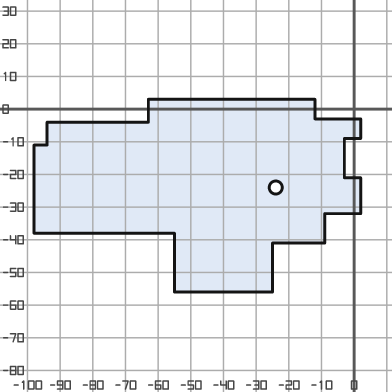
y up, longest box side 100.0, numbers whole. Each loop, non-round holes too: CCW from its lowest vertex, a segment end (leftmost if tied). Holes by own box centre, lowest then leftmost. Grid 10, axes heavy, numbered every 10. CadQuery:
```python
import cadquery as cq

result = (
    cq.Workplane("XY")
    .moveTo(-55.0, -56.0)
    .lineTo(-25.0, -56.0)
    .lineTo(-25.0, -41.0)
    .lineTo(-9.0, -41.0)
    .lineTo(-9.0, -32.0)
    .lineTo(2.0, -32.0)
    .lineTo(2.0, -21.0)
    .lineTo(-3.0, -21.0)
    .lineTo(-3.0, -9.0)
    .lineTo(2.0, -9.0)
    .lineTo(2.0, -3.0)
    .lineTo(-12.0, -3.0)
    .lineTo(-12.0, 3.0)
    .lineTo(-63.0, 3.0)
    .lineTo(-63.0, -4.0)
    .lineTo(-94.0, -4.0)
    .lineTo(-94.0, -11.0)
    .lineTo(-98.0, -11.0)
    .lineTo(-98.0, -38.0)
    .lineTo(-55.0, -38.0)
    .close()
    .moveTo(-24.0, -24.0)
    .circle(2.0)
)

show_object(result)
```